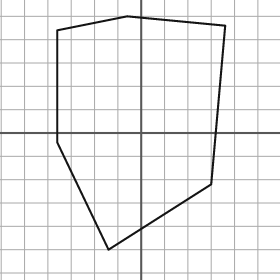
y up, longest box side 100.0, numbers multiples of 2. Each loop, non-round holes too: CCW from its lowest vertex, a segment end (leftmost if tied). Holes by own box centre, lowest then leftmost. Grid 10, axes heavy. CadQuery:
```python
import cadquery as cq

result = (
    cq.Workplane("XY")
    .moveTo(-14.0, -50.0)
    .lineTo(30.0, -22.0)
    .lineTo(36.0, 46.0)
    .lineTo(-6.0, 50.0)
    .lineTo(-36.0, 44.0)
    .lineTo(-36.0, -4.0)
    .close()
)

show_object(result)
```